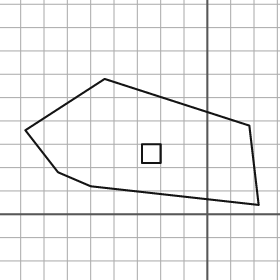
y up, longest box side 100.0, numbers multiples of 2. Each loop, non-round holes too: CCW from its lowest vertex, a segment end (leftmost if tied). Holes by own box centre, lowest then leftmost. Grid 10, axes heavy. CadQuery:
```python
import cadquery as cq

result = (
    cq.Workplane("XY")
    .moveTo(22.0, 4.0)
    .lineTo(18.0, 38.0)
    .lineTo(-44.0, 58.0)
    .lineTo(-78.0, 36.0)
    .lineTo(-64.0, 18.0)
    .lineTo(-50.0, 12.0)
    .close()
    .moveTo(-28.0, 22.0)
    .lineTo(-20.0, 22.0)
    .lineTo(-20.0, 30.0)
    .lineTo(-28.0, 30.0)
    .close()
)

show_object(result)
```